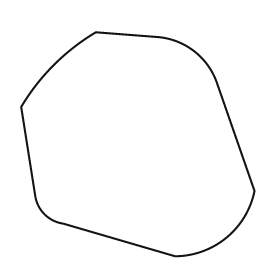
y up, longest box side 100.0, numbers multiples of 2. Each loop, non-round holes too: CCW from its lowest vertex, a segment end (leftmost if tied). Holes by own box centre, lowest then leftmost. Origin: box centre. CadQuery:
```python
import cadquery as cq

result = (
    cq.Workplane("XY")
    .moveTo(16.0, -48.0)
    .threePointArc((38.0, -40.0), (50.0, -20.0))
    .lineTo(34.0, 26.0)
    .threePointArc((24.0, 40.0), (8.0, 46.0))
    .lineTo(-18.0, 48.0)
    .threePointArc((-36.0, 34.0), (-50.0, 16.0))
    .lineTo(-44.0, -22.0)
    .threePointArc((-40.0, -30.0), (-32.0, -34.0))
    .close()
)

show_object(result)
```